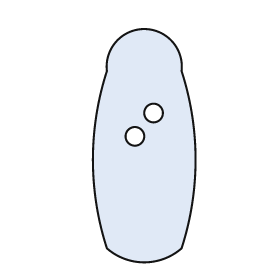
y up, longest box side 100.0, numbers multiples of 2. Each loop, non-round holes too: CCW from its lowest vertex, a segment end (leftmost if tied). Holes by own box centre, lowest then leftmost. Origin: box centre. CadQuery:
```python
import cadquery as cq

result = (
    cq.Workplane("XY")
    .moveTo(-16.0, -44.0)
    .threePointArc((0.0, -50.0), (16.0, -44.0))
    .threePointArc((22.0, -6.0), (16.0, 32.0))
    .threePointArc((0.0, 50.0), (-16.0, 32.0))
    .threePointArc((-22.0, -6.0), (-16.0, -44.0))
    .close()
    .moveTo(-4.0, 4.0)
    .circle(4.0)
    .moveTo(4.0, 14.0)
    .circle(4.0)
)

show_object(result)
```